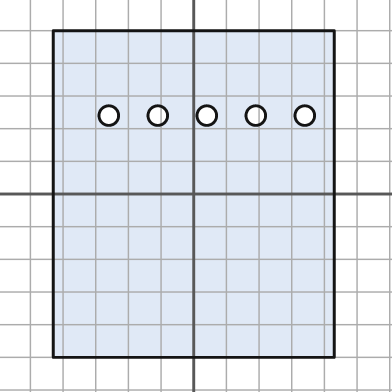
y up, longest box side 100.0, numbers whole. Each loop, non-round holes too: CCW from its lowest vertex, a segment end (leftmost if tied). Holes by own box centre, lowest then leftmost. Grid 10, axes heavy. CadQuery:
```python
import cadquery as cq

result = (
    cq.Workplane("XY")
    .moveTo(-43.0, -50.0)
    .lineTo(43.0, -50.0)
    .lineTo(43.0, 50.0)
    .lineTo(-43.0, 50.0)
    .close()
    .moveTo(-26.0, 24.0)
    .circle(3.0)
    .moveTo(-11.0, 24.0)
    .circle(3.0)
    .moveTo(4.0, 24.0)
    .circle(3.0)
    .moveTo(19.0, 24.0)
    .circle(3.0)
    .moveTo(34.0, 24.0)
    .circle(3.0)
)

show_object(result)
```